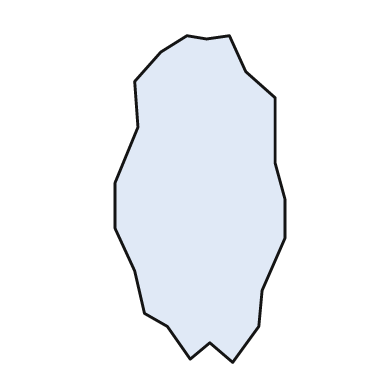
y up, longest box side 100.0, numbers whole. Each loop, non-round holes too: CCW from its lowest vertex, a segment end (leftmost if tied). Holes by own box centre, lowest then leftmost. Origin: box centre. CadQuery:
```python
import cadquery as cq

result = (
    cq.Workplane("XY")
    .moveTo(10.0, -50.0)
    .lineTo(18.0, -39.0)
    .lineTo(19.0, -28.0)
    .lineTo(26.0, -12.0)
    .lineTo(26.0, 0.0)
    .lineTo(23.0, 11.0)
    .lineTo(23.0, 31.0)
    .lineTo(14.0, 39.0)
    .lineTo(9.0, 50.0)
    .lineTo(2.0, 49.0)
    .lineTo(-4.0, 50.0)
    .lineTo(-12.0, 45.0)
    .lineTo(-20.0, 36.0)
    .lineTo(-19.0, 22.0)
    .lineTo(-26.0, 5.0)
    .lineTo(-26.0, -9.0)
    .lineTo(-20.0, -22.0)
    .lineTo(-17.0, -35.0)
    .lineTo(-10.0, -39.0)
    .lineTo(-3.0, -49.0)
    .lineTo(3.0, -44.0)
    .close()
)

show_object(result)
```